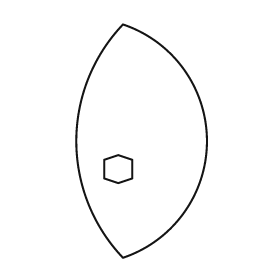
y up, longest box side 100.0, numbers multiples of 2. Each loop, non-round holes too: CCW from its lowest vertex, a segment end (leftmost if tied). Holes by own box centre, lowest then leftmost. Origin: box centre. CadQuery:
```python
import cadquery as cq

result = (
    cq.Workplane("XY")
    .moveTo(-8.0, -50.0)
    .threePointArc((28.0, 0.0), (-8.0, 50.0))
    .threePointArc((-28.0, 0.0), (-8.0, -50.0))
    .close()
    .moveTo(-10.0, -18.0)
    .lineTo(-4.0, -16.0)
    .lineTo(-4.0, -8.0)
    .lineTo(-10.0, -6.0)
    .lineTo(-16.0, -8.0)
    .lineTo(-16.0, -16.0)
    .close()
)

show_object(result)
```